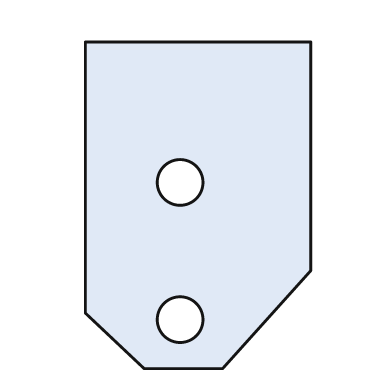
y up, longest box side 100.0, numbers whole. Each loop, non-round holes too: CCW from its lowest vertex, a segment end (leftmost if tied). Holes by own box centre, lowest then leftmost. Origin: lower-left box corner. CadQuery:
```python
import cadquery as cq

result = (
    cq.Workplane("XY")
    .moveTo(18.0, 0.0)
    .lineTo(42.0, 0.0)
    .lineTo(69.0, 30.0)
    .lineTo(69.0, 100.0)
    .lineTo(0.0, 100.0)
    .lineTo(0.0, 17.0)
    .close()
    .moveTo(29.0, 15.0)
    .circle(7.0)
    .moveTo(29.0, 57.0)
    .circle(7.0)
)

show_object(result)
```